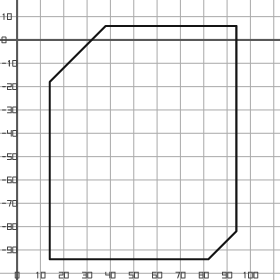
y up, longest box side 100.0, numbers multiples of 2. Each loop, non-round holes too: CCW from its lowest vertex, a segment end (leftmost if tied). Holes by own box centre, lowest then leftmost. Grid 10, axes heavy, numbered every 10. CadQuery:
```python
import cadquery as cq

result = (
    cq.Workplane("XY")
    .moveTo(14.0, -94.0)
    .lineTo(82.0, -94.0)
    .lineTo(94.0, -82.0)
    .lineTo(94.0, 6.0)
    .lineTo(38.0, 6.0)
    .lineTo(14.0, -18.0)
    .close()
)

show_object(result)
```